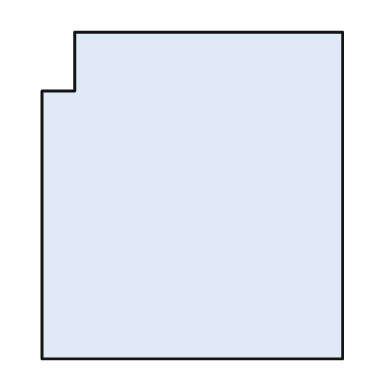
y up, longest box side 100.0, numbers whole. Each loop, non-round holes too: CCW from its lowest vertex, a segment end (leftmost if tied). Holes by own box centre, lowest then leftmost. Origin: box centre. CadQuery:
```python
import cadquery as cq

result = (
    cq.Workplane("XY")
    .moveTo(-46.0, -50.0)
    .lineTo(46.0, -50.0)
    .lineTo(46.0, 50.0)
    .lineTo(-36.0, 50.0)
    .lineTo(-36.0, 32.0)
    .lineTo(-46.0, 32.0)
    .close()
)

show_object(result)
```